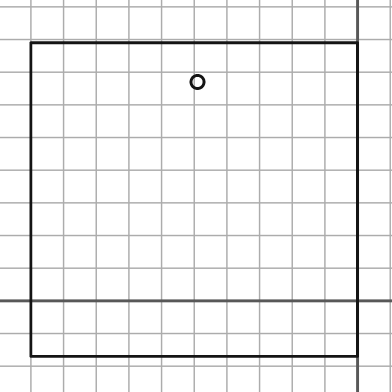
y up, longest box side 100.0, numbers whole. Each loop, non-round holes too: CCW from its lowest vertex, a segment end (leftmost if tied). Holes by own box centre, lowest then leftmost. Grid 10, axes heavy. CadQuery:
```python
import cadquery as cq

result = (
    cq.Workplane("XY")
    .moveTo(-100.0, -17.0)
    .lineTo(0.0, -17.0)
    .lineTo(0.0, 79.0)
    .lineTo(-100.0, 79.0)
    .close()
    .moveTo(-49.0, 67.0)
    .circle(2.0)
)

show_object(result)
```